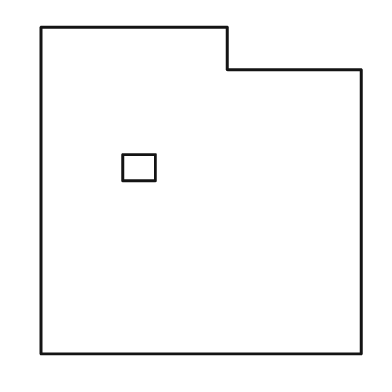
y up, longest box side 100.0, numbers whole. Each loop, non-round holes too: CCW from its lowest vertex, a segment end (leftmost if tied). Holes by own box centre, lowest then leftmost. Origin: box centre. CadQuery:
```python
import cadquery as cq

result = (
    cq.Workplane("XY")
    .moveTo(-49.0, -50.0)
    .lineTo(49.0, -50.0)
    .lineTo(49.0, 37.0)
    .lineTo(8.0, 37.0)
    .lineTo(8.0, 50.0)
    .lineTo(-49.0, 50.0)
    .close()
    .moveTo(-24.0, 3.0)
    .lineTo(-14.0, 3.0)
    .lineTo(-14.0, 11.0)
    .lineTo(-24.0, 11.0)
    .close()
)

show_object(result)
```